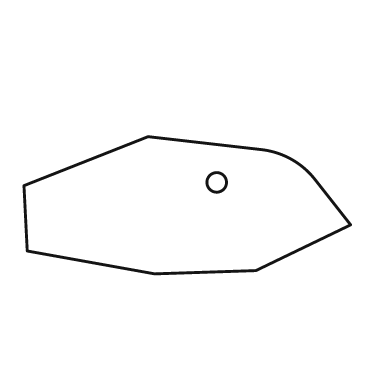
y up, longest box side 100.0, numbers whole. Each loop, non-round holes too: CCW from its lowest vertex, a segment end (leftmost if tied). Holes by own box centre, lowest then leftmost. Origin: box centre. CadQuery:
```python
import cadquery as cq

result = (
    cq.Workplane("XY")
    .moveTo(-10.0, -21.0)
    .lineTo(21.0, -20.0)
    .lineTo(50.0, -6.0)
    .lineTo(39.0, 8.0)
    .threePointArc((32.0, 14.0), (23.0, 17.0))
    .lineTo(-12.0, 21.0)
    .lineTo(-50.0, 6.0)
    .lineTo(-49.0, -14.0)
    .close()
    .moveTo(9.0, 7.0)
    .circle(3.0)
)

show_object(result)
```